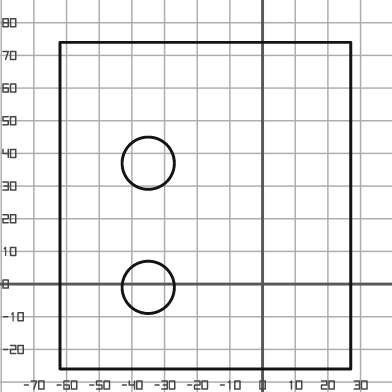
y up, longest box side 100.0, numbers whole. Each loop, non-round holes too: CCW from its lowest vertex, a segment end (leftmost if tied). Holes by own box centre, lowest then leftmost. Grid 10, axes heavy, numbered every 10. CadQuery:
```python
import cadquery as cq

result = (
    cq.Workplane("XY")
    .moveTo(-62.0, -26.0)
    .lineTo(27.0, -26.0)
    .lineTo(27.0, 74.0)
    .lineTo(-62.0, 74.0)
    .close()
    .moveTo(-35.0, -1.0)
    .circle(8.0)
    .moveTo(-35.0, 37.0)
    .circle(8.0)
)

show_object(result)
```